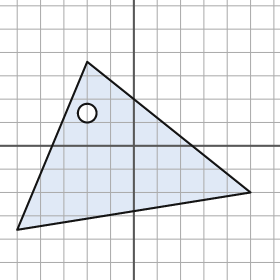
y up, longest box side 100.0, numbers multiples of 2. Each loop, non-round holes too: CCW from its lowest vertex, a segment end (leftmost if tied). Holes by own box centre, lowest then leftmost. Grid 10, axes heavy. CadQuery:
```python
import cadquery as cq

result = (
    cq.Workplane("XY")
    .moveTo(-50.0, -36.0)
    .lineTo(50.0, -20.0)
    .lineTo(-20.0, 36.0)
    .close()
    .moveTo(-20.0, 14.0)
    .circle(4.0)
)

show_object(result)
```